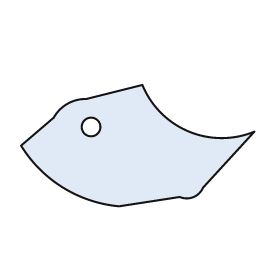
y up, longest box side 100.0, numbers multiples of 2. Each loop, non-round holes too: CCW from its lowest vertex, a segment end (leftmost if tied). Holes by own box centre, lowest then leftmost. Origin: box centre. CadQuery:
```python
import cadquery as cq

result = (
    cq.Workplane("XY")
    .moveTo(-8.0, -26.0)
    .lineTo(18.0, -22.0)
    .threePointArc((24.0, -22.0), (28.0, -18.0))
    .lineTo(50.0, 6.0)
    .threePointArc((22.0, 6.0), (2.0, 26.0))
    .lineTo(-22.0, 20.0)
    .threePointArc((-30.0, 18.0), (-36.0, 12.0))
    .lineTo(-50.0, 0.0)
    .threePointArc((-32.0, -18.0), (-8.0, -26.0))
    .close()
    .moveTo(-20.0, 8.0)
    .circle(4.0)
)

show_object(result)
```